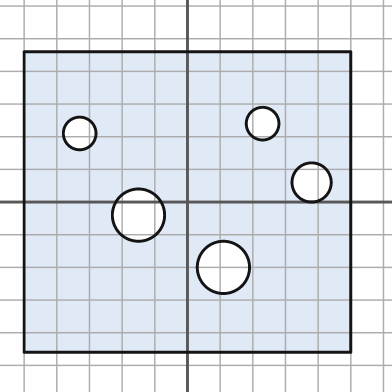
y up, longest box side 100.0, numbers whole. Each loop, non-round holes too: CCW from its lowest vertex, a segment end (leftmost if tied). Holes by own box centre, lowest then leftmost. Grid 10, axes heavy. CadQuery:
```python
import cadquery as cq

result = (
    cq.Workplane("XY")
    .moveTo(-50.0, -46.0)
    .lineTo(50.0, -46.0)
    .lineTo(50.0, 46.0)
    .lineTo(-50.0, 46.0)
    .close()
    .moveTo(11.0, -20.0)
    .circle(8.0)
    .moveTo(-15.0, -4.0)
    .circle(8.0)
    .moveTo(38.0, 6.0)
    .circle(6.0)
    .moveTo(-33.0, 21.0)
    .circle(5.0)
    .moveTo(23.0, 24.0)
    .circle(5.0)
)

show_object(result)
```